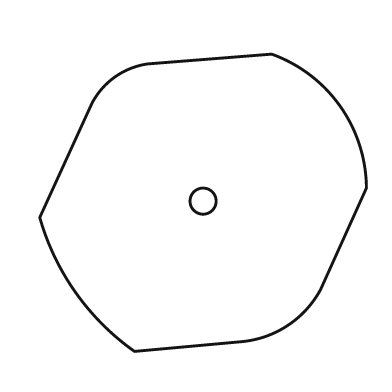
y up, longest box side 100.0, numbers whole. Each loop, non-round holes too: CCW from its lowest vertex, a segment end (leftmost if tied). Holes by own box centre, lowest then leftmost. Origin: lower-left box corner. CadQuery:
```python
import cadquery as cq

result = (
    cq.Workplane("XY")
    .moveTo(29.0, 0.0)
    .lineTo(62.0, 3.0)
    .threePointArc((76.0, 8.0), (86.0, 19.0))
    .lineTo(100.0, 50.0)
    .threePointArc((92.0, 75.0), (71.0, 91.0))
    .lineTo(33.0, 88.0)
    .threePointArc((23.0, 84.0), (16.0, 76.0))
    .lineTo(0.0, 41.0)
    .threePointArc((11.0, 18.0), (29.0, 0.0))
    .close()
    .moveTo(50.0, 46.0)
    .circle(4.0)
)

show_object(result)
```